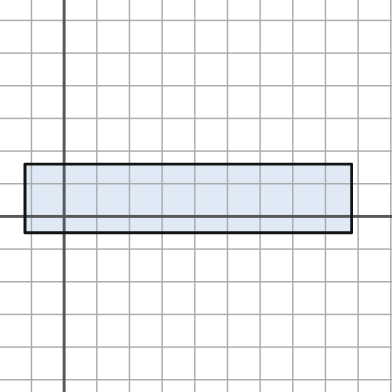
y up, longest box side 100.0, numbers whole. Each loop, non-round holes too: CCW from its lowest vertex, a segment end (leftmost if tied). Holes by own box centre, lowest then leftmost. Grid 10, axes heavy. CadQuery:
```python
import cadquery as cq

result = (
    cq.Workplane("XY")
    .moveTo(-12.0, -5.0)
    .lineTo(88.0, -5.0)
    .lineTo(88.0, 16.0)
    .lineTo(-12.0, 16.0)
    .close()
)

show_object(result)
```